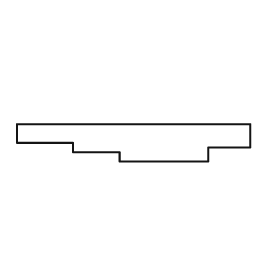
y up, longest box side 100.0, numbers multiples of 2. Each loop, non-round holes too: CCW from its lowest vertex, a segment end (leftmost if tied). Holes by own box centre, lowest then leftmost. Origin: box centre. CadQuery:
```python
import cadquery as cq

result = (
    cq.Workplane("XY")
    .moveTo(-6.0, -8.0)
    .lineTo(32.0, -8.0)
    .lineTo(32.0, -2.0)
    .lineTo(50.0, -2.0)
    .lineTo(50.0, 8.0)
    .lineTo(-50.0, 8.0)
    .lineTo(-50.0, 0.0)
    .lineTo(-26.0, 0.0)
    .lineTo(-26.0, -4.0)
    .lineTo(-6.0, -4.0)
    .close()
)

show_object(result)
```